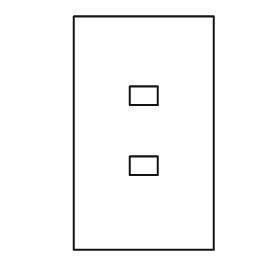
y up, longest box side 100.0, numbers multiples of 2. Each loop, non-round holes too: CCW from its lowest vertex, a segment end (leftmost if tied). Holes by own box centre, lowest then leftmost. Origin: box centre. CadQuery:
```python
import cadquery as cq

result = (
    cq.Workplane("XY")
    .moveTo(-30.0, -50.0)
    .lineTo(30.0, -50.0)
    .lineTo(30.0, 50.0)
    .lineTo(-30.0, 50.0)
    .close()
    .moveTo(-6.0, -18.0)
    .lineTo(6.0, -18.0)
    .lineTo(6.0, -10.0)
    .lineTo(-6.0, -10.0)
    .close()
    .moveTo(-6.0, 12.0)
    .lineTo(6.0, 12.0)
    .lineTo(6.0, 20.0)
    .lineTo(-6.0, 20.0)
    .close()
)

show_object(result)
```